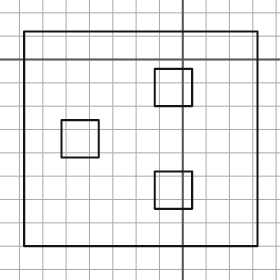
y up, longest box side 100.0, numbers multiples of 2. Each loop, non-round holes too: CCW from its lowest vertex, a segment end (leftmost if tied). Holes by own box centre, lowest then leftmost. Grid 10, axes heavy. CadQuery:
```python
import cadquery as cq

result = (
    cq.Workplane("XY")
    .moveTo(-68.0, -80.0)
    .lineTo(32.0, -80.0)
    .lineTo(32.0, 12.0)
    .lineTo(-68.0, 12.0)
    .close()
    .moveTo(-12.0, -64.0)
    .lineTo(4.0, -64.0)
    .lineTo(4.0, -48.0)
    .lineTo(-12.0, -48.0)
    .close()
    .moveTo(-52.0, -42.0)
    .lineTo(-36.0, -42.0)
    .lineTo(-36.0, -26.0)
    .lineTo(-52.0, -26.0)
    .close()
    .moveTo(-12.0, -20.0)
    .lineTo(4.0, -20.0)
    .lineTo(4.0, -4.0)
    .lineTo(-12.0, -4.0)
    .close()
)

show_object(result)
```